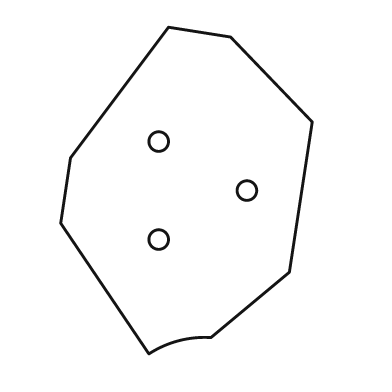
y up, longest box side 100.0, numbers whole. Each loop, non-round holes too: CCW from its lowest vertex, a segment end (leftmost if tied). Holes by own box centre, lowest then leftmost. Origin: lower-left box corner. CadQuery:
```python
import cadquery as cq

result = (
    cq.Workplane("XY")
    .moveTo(27.0, 0.0)
    .threePointArc((36.0, 4.0), (46.0, 5.0))
    .lineTo(70.0, 25.0)
    .lineTo(77.0, 71.0)
    .lineTo(52.0, 97.0)
    .lineTo(33.0, 100.0)
    .lineTo(3.0, 60.0)
    .lineTo(0.0, 40.0)
    .close()
    .moveTo(30.0, 35.0)
    .circle(3.0)
    .moveTo(57.0, 50.0)
    .circle(3.0)
    .moveTo(30.0, 65.0)
    .circle(3.0)
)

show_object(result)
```